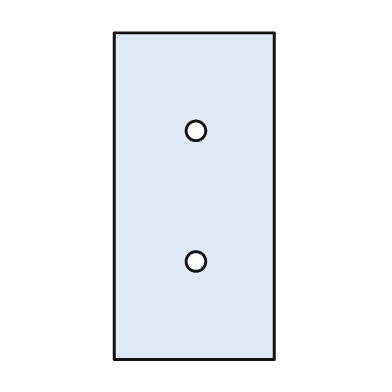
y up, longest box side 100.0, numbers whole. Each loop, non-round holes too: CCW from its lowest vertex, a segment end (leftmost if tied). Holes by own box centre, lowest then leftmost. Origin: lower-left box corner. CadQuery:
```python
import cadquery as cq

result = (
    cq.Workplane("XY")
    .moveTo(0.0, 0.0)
    .lineTo(49.0, 0.0)
    .lineTo(49.0, 100.0)
    .lineTo(0.0, 100.0)
    .close()
    .moveTo(25.0, 30.0)
    .circle(3.0)
    .moveTo(25.0, 70.0)
    .circle(3.0)
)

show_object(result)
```